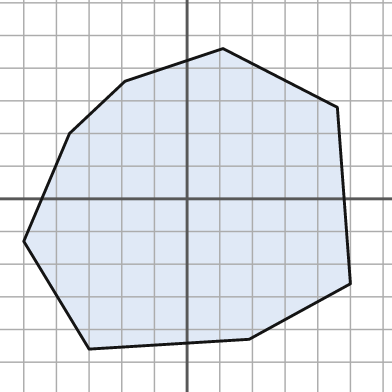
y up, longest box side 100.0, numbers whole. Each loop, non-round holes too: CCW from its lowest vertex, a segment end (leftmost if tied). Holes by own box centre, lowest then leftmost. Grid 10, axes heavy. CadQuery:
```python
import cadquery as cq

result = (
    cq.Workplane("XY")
    .moveTo(-30.0, -46.0)
    .lineTo(19.0, -43.0)
    .lineTo(50.0, -26.0)
    .lineTo(46.0, 28.0)
    .lineTo(11.0, 46.0)
    .lineTo(-19.0, 36.0)
    .lineTo(-36.0, 20.0)
    .lineTo(-50.0, -13.0)
    .close()
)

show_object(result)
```